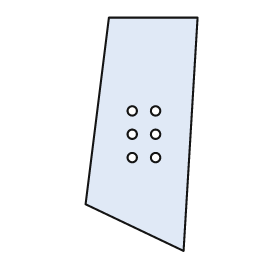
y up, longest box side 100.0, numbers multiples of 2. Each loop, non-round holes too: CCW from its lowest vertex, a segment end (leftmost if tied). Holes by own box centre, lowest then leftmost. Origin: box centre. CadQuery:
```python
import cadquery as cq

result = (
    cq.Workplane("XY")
    .moveTo(18.0, -50.0)
    .lineTo(24.0, 50.0)
    .lineTo(-14.0, 50.0)
    .lineTo(-24.0, -30.0)
    .close()
    .moveTo(-4.0, -10.0)
    .circle(2.0)
    .moveTo(6.0, -10.0)
    .circle(2.0)
    .moveTo(-4.0, 0.0)
    .circle(2.0)
    .moveTo(6.0, 0.0)
    .circle(2.0)
    .moveTo(-4.0, 10.0)
    .circle(2.0)
    .moveTo(6.0, 10.0)
    .circle(2.0)
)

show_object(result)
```